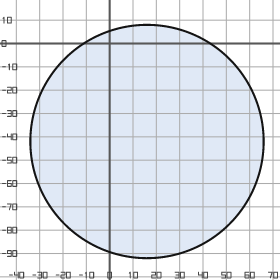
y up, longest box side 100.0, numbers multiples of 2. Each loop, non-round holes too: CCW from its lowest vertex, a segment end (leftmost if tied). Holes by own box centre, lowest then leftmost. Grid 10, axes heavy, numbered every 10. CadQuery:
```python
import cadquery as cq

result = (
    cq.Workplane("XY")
    .moveTo(16.0, -42.0)
    .circle(50.0)
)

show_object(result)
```